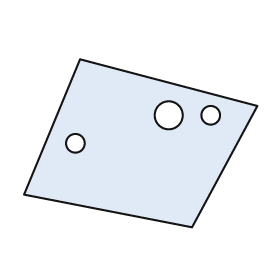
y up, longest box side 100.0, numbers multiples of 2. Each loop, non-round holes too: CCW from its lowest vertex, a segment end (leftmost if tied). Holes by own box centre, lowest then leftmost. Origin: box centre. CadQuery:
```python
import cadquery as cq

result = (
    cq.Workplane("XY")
    .moveTo(22.0, -36.0)
    .lineTo(50.0, 16.0)
    .lineTo(-26.0, 36.0)
    .lineTo(-50.0, -22.0)
    .close()
    .moveTo(-28.0, 0.0)
    .circle(4.0)
    .moveTo(12.0, 12.0)
    .circle(6.0)
    .moveTo(30.0, 12.0)
    .circle(4.0)
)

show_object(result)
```